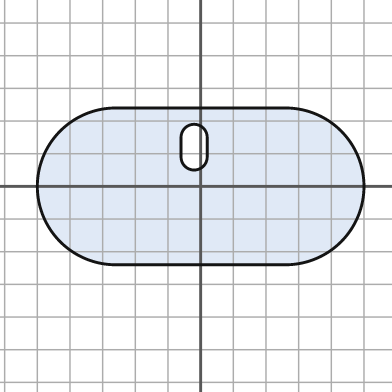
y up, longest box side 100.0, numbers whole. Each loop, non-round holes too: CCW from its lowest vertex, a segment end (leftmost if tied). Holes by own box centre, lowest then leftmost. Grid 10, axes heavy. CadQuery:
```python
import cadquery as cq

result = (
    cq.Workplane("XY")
    .moveTo(-26.0, -24.0)
    .lineTo(26.0, -24.0)
    .threePointArc((50.0, 0.0), (26.0, 24.0))
    .lineTo(-26.0, 24.0)
    .threePointArc((-50.0, 0.0), (-26.0, -24.0))
    .close()
    .moveTo(-6.0, 9.0)
    .threePointArc((-2.0, 5.0), (2.0, 9.0))
    .lineTo(2.0, 15.0)
    .threePointArc((-2.0, 19.0), (-6.0, 15.0))
    .close()
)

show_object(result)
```